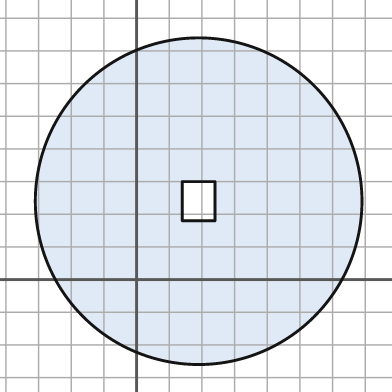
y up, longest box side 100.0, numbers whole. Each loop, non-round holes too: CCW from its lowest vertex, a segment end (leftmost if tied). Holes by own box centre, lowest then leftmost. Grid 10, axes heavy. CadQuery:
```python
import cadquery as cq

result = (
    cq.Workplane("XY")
    .moveTo(19.0, 24.0)
    .circle(50.0)
    .moveTo(14.0, 18.0)
    .lineTo(24.0, 18.0)
    .lineTo(24.0, 30.0)
    .lineTo(14.0, 30.0)
    .close()
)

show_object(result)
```